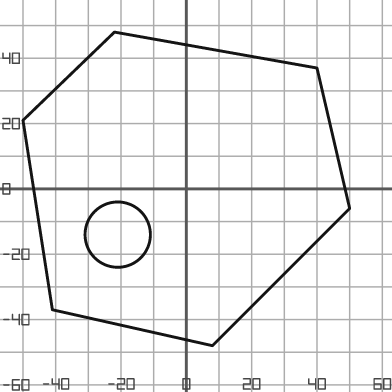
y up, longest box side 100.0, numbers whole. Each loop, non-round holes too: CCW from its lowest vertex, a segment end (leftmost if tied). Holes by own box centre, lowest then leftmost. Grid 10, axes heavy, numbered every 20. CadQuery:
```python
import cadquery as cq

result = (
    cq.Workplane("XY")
    .moveTo(8.0, -48.0)
    .lineTo(50.0, -6.0)
    .lineTo(40.0, 37.0)
    .lineTo(-22.0, 48.0)
    .lineTo(-50.0, 21.0)
    .lineTo(-41.0, -37.0)
    .close()
    .moveTo(-21.0, -14.0)
    .circle(10.0)
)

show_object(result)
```